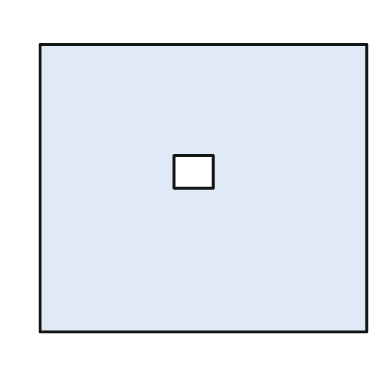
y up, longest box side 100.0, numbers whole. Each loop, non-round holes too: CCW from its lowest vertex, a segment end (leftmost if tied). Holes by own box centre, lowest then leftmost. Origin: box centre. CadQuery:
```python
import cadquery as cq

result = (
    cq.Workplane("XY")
    .moveTo(-50.0, -44.0)
    .lineTo(50.0, -44.0)
    .lineTo(50.0, 44.0)
    .lineTo(-50.0, 44.0)
    .close()
    .moveTo(-9.0, 0.0)
    .lineTo(3.0, 0.0)
    .lineTo(3.0, 10.0)
    .lineTo(-9.0, 10.0)
    .close()
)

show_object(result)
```